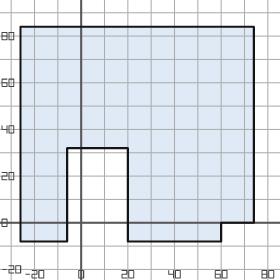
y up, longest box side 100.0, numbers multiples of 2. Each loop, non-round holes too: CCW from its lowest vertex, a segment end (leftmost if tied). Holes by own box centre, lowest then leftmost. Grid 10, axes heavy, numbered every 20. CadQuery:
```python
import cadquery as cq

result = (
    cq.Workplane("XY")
    .moveTo(-26.0, -8.0)
    .lineTo(-6.0, -8.0)
    .lineTo(-6.0, 32.0)
    .lineTo(20.0, 32.0)
    .lineTo(20.0, -8.0)
    .lineTo(60.0, -8.0)
    .lineTo(60.0, 0.0)
    .lineTo(74.0, 0.0)
    .lineTo(74.0, 84.0)
    .lineTo(-26.0, 84.0)
    .close()
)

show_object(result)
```